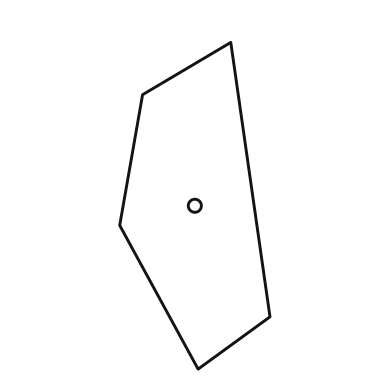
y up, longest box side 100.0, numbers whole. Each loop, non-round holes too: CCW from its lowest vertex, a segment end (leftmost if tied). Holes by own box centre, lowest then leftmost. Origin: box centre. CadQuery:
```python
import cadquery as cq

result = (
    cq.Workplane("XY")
    .moveTo(1.0, -50.0)
    .lineTo(23.0, -34.0)
    .lineTo(11.0, 50.0)
    .lineTo(-16.0, 34.0)
    .lineTo(-23.0, -6.0)
    .close()
    .moveTo(0.0, 0.0)
    .circle(2.0)
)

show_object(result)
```